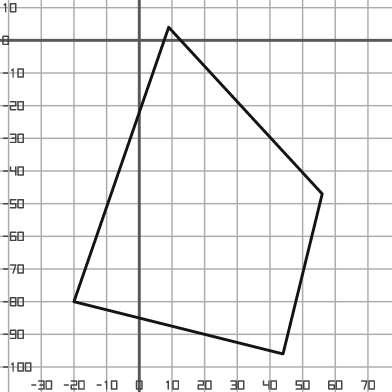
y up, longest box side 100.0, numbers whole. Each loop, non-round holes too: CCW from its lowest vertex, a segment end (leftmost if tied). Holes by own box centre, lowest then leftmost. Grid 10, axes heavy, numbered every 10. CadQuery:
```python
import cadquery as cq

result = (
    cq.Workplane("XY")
    .moveTo(44.0, -96.0)
    .lineTo(56.0, -47.0)
    .lineTo(9.0, 4.0)
    .lineTo(-20.0, -80.0)
    .close()
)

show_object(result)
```